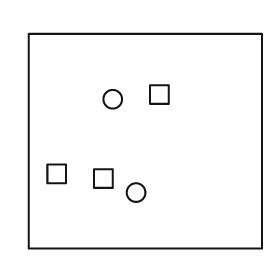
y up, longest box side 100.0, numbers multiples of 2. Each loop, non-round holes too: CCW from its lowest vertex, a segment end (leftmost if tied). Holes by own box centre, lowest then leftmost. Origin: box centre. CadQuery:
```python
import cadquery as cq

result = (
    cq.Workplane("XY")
    .moveTo(-50.0, -46.0)
    .lineTo(50.0, -46.0)
    .lineTo(50.0, 46.0)
    .lineTo(-50.0, 46.0)
    .close()
    .moveTo(-4.0, -22.0)
    .circle(4.0)
    .moveTo(-22.0, -20.0)
    .lineTo(-14.0, -20.0)
    .lineTo(-14.0, -12.0)
    .lineTo(-22.0, -12.0)
    .close()
    .moveTo(-42.0, -18.0)
    .lineTo(-34.0, -18.0)
    .lineTo(-34.0, -10.0)
    .lineTo(-42.0, -10.0)
    .close()
    .moveTo(-14.0, 18.0)
    .circle(4.0)
    .moveTo(2.0, 16.0)
    .lineTo(10.0, 16.0)
    .lineTo(10.0, 24.0)
    .lineTo(2.0, 24.0)
    .close()
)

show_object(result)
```